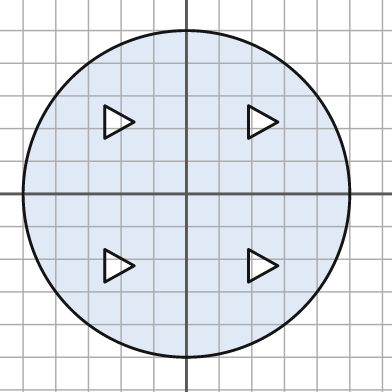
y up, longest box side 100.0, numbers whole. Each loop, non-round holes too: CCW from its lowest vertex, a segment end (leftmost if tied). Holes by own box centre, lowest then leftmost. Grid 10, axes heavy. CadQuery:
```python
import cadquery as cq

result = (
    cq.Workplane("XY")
    .moveTo(0.0, 0.0)
    .circle(50.0)
    .moveTo(-25.0, -27.0)
    .lineTo(-16.0, -22.0)
    .lineTo(-25.0, -17.0)
    .close()
    .moveTo(19.0, -27.0)
    .lineTo(28.0, -22.0)
    .lineTo(19.0, -17.0)
    .close()
    .moveTo(-25.0, 17.0)
    .lineTo(-16.0, 22.0)
    .lineTo(-25.0, 27.0)
    .close()
    .moveTo(19.0, 17.0)
    .lineTo(28.0, 22.0)
    .lineTo(19.0, 27.0)
    .close()
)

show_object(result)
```